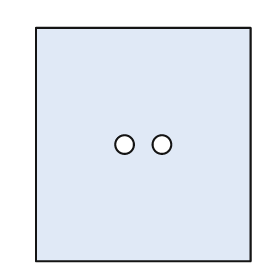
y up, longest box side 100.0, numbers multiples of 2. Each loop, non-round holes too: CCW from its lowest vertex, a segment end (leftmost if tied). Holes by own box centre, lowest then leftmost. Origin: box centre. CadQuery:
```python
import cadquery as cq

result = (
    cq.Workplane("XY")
    .moveTo(-46.0, -50.0)
    .lineTo(46.0, -50.0)
    .lineTo(46.0, 50.0)
    .lineTo(-46.0, 50.0)
    .close()
    .moveTo(-8.0, 0.0)
    .circle(4.0)
    .moveTo(8.0, 0.0)
    .circle(4.0)
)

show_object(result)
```